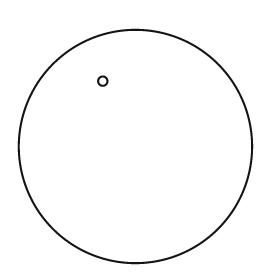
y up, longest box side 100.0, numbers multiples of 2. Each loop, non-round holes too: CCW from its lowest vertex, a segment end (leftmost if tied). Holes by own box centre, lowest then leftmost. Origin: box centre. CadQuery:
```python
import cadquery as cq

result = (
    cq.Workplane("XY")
    .moveTo(0.0, 0.0)
    .circle(50.0)
    .moveTo(-14.0, 28.0)
    .circle(2.0)
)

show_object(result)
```